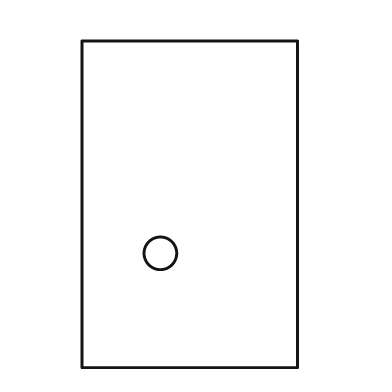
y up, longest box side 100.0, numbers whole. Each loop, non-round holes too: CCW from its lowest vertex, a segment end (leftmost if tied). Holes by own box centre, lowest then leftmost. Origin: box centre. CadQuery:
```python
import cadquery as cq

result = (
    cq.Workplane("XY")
    .moveTo(-33.0, -50.0)
    .lineTo(33.0, -50.0)
    .lineTo(33.0, 50.0)
    .lineTo(-33.0, 50.0)
    .close()
    .moveTo(-9.0, -15.0)
    .circle(5.0)
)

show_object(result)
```